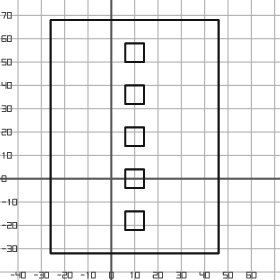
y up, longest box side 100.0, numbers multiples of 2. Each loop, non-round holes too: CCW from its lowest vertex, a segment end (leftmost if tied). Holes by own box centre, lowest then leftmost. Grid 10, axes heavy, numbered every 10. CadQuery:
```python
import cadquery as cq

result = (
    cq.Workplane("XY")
    .moveTo(-26.0, -32.0)
    .lineTo(46.0, -32.0)
    .lineTo(46.0, 68.0)
    .lineTo(-26.0, 68.0)
    .close()
    .moveTo(6.0, -22.0)
    .lineTo(14.0, -22.0)
    .lineTo(14.0, -14.0)
    .lineTo(6.0, -14.0)
    .close()
    .moveTo(6.0, -4.0)
    .lineTo(14.0, -4.0)
    .lineTo(14.0, 4.0)
    .lineTo(6.0, 4.0)
    .close()
    .moveTo(6.0, 14.0)
    .lineTo(14.0, 14.0)
    .lineTo(14.0, 22.0)
    .lineTo(6.0, 22.0)
    .close()
    .moveTo(6.0, 32.0)
    .lineTo(14.0, 32.0)
    .lineTo(14.0, 40.0)
    .lineTo(6.0, 40.0)
    .close()
    .moveTo(6.0, 50.0)
    .lineTo(14.0, 50.0)
    .lineTo(14.0, 58.0)
    .lineTo(6.0, 58.0)
    .close()
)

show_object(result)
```